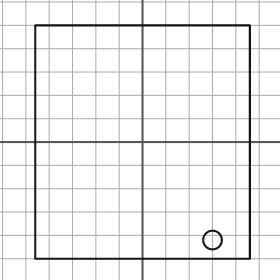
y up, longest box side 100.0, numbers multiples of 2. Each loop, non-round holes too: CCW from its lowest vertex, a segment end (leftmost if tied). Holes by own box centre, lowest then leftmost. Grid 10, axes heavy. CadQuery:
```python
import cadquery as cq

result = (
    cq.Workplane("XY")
    .moveTo(-46.0, -50.0)
    .lineTo(46.0, -50.0)
    .lineTo(46.0, 50.0)
    .lineTo(-46.0, 50.0)
    .close()
    .moveTo(30.0, -42.0)
    .circle(4.0)
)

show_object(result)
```